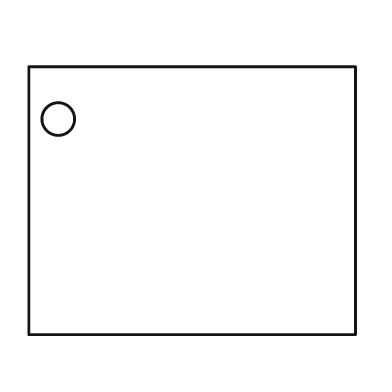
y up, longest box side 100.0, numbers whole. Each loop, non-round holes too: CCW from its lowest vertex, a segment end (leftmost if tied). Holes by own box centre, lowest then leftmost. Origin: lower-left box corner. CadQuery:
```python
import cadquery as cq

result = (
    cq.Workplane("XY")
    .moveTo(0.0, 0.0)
    .lineTo(100.0, 0.0)
    .lineTo(100.0, 82.0)
    .lineTo(0.0, 82.0)
    .close()
    .moveTo(9.0, 66.0)
    .circle(5.0)
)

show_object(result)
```